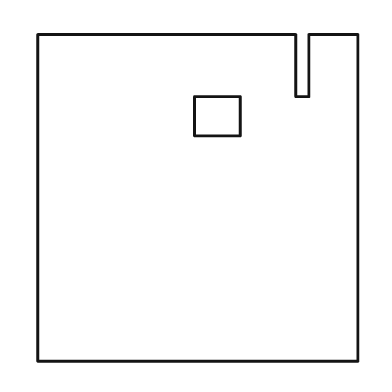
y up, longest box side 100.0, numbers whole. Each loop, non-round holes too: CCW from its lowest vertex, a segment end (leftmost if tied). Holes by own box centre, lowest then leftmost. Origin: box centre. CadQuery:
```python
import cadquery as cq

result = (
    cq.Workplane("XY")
    .moveTo(-49.0, -50.0)
    .lineTo(49.0, -50.0)
    .lineTo(49.0, 50.0)
    .lineTo(34.0, 50.0)
    .lineTo(34.0, 31.0)
    .lineTo(30.0, 31.0)
    .lineTo(30.0, 50.0)
    .lineTo(-49.0, 50.0)
    .close()
    .moveTo(-1.0, 19.0)
    .lineTo(13.0, 19.0)
    .lineTo(13.0, 31.0)
    .lineTo(-1.0, 31.0)
    .close()
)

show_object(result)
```